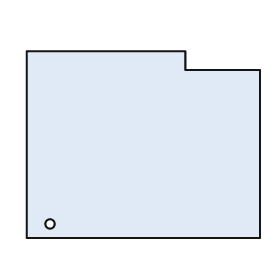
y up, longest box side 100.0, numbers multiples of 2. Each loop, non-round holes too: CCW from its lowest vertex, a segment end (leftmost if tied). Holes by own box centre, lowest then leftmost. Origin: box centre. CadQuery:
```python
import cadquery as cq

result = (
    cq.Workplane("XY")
    .moveTo(-50.0, -40.0)
    .lineTo(50.0, -40.0)
    .lineTo(50.0, 32.0)
    .lineTo(18.0, 32.0)
    .lineTo(18.0, 40.0)
    .lineTo(-50.0, 40.0)
    .close()
    .moveTo(-40.0, -34.0)
    .circle(2.0)
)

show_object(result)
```